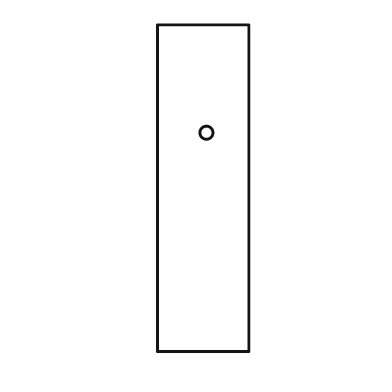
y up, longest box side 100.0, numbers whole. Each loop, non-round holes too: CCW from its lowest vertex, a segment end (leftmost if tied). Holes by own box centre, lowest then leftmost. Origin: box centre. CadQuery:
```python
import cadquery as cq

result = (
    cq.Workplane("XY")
    .moveTo(-14.0, -50.0)
    .lineTo(14.0, -50.0)
    .lineTo(14.0, 50.0)
    .lineTo(-14.0, 50.0)
    .close()
    .moveTo(1.0, 17.0)
    .circle(2.0)
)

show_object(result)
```